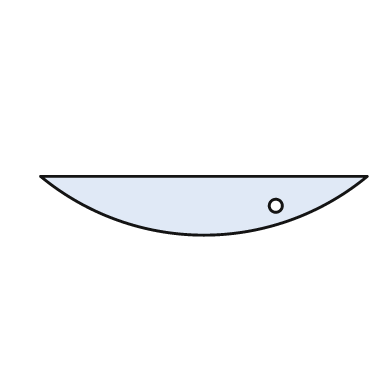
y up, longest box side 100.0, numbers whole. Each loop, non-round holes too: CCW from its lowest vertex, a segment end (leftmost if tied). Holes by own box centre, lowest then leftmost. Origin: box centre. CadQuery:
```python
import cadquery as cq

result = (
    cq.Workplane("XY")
    .moveTo(-50.0, 9.0)
    .threePointArc((0.0, -9.0), (50.0, 9.0))
    .close()
    .moveTo(22.0, 0.0)
    .circle(2.0)
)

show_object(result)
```